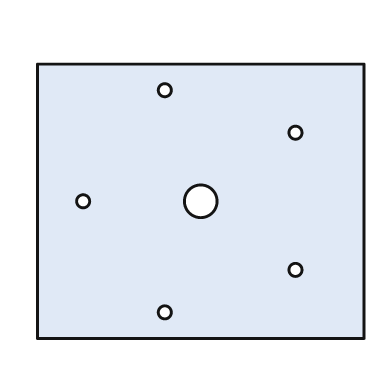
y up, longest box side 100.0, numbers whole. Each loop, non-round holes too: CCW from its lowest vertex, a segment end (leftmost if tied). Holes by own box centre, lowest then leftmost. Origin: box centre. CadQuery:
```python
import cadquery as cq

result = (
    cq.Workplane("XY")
    .moveTo(-50.0, -42.0)
    .lineTo(50.0, -42.0)
    .lineTo(50.0, 42.0)
    .lineTo(-50.0, 42.0)
    .close()
    .moveTo(-11.0, -34.0)
    .circle(2.0)
    .moveTo(29.0, -21.0)
    .circle(2.0)
    .moveTo(-36.0, 0.0)
    .circle(2.0)
    .moveTo(0.0, 0.0)
    .circle(5.0)
    .moveTo(29.0, 21.0)
    .circle(2.0)
    .moveTo(-11.0, 34.0)
    .circle(2.0)
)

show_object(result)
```